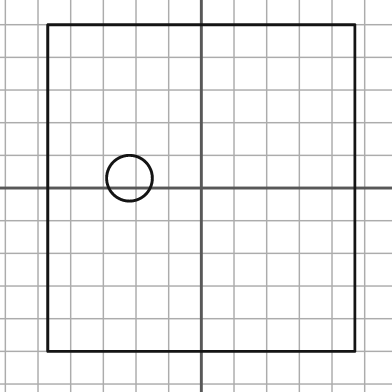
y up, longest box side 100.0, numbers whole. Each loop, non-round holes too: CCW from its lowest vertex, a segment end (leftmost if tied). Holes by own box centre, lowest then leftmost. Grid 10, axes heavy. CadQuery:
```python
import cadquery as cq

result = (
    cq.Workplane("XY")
    .moveTo(-47.0, -50.0)
    .lineTo(47.0, -50.0)
    .lineTo(47.0, 50.0)
    .lineTo(-47.0, 50.0)
    .close()
    .moveTo(-22.0, 3.0)
    .circle(7.0)
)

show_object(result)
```